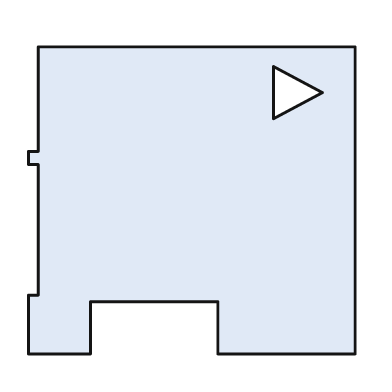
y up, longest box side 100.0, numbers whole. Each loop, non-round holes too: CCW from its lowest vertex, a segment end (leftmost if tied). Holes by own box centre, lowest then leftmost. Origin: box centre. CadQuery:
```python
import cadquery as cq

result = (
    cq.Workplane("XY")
    .moveTo(-50.0, -47.0)
    .lineTo(-31.0, -47.0)
    .lineTo(-31.0, -31.0)
    .lineTo(8.0, -31.0)
    .lineTo(8.0, -47.0)
    .lineTo(50.0, -47.0)
    .lineTo(50.0, 47.0)
    .lineTo(-47.0, 47.0)
    .lineTo(-47.0, 15.0)
    .lineTo(-50.0, 15.0)
    .lineTo(-50.0, 11.0)
    .lineTo(-47.0, 11.0)
    .lineTo(-47.0, -29.0)
    .lineTo(-50.0, -29.0)
    .close()
    .moveTo(25.0, 25.0)
    .lineTo(40.0, 33.0)
    .lineTo(25.0, 41.0)
    .close()
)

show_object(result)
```